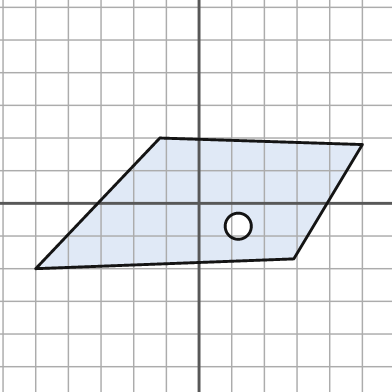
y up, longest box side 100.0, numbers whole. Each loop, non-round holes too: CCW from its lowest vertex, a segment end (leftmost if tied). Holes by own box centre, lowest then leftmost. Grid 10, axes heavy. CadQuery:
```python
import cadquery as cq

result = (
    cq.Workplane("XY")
    .moveTo(-50.0, -20.0)
    .lineTo(29.0, -17.0)
    .lineTo(50.0, 18.0)
    .lineTo(-12.0, 20.0)
    .close()
    .moveTo(12.0, -7.0)
    .circle(4.0)
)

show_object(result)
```